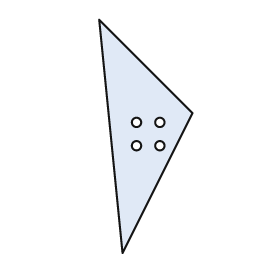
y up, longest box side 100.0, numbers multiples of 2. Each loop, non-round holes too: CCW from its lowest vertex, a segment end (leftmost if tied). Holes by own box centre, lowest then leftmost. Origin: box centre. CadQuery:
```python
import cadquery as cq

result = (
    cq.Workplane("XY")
    .moveTo(-10.0, -50.0)
    .lineTo(20.0, 10.0)
    .lineTo(-20.0, 50.0)
    .close()
    .moveTo(-4.0, -4.0)
    .circle(2.0)
    .moveTo(6.0, -4.0)
    .circle(2.0)
    .moveTo(-4.0, 6.0)
    .circle(2.0)
    .moveTo(6.0, 6.0)
    .circle(2.0)
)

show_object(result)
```